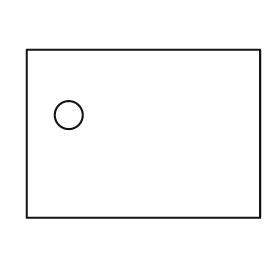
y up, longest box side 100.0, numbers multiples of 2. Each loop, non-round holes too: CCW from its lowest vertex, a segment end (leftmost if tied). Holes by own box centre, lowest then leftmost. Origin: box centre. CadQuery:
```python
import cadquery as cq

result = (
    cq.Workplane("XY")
    .moveTo(-50.0, -36.0)
    .lineTo(50.0, -36.0)
    .lineTo(50.0, 36.0)
    .lineTo(-50.0, 36.0)
    .close()
    .moveTo(-32.0, 8.0)
    .circle(6.0)
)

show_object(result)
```